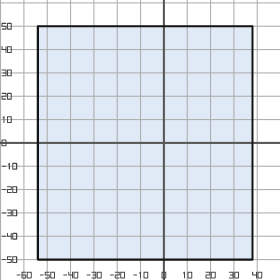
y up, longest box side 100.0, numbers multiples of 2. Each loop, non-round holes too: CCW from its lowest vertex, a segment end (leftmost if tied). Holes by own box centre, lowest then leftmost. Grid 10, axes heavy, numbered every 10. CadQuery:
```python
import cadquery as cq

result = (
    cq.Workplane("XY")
    .moveTo(-54.0, -50.0)
    .lineTo(38.0, -50.0)
    .lineTo(38.0, 50.0)
    .lineTo(-54.0, 50.0)
    .close()
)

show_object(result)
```